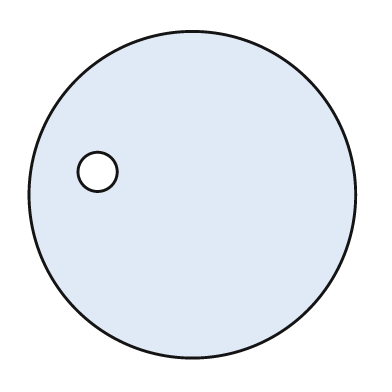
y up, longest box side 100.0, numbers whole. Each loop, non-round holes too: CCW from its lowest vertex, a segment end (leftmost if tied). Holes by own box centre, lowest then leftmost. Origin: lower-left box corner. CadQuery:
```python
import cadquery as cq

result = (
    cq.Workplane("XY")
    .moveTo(50.0, 50.0)
    .circle(50.0)
    .moveTo(21.0, 57.0)
    .circle(6.0)
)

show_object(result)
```